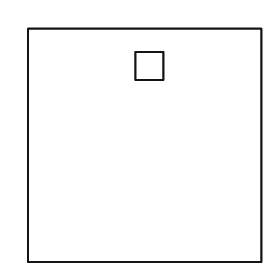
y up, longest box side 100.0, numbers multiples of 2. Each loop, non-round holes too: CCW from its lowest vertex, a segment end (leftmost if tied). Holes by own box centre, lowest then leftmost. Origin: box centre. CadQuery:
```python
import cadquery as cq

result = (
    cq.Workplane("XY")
    .moveTo(-50.0, -50.0)
    .lineTo(50.0, -50.0)
    .lineTo(50.0, 50.0)
    .lineTo(-50.0, 50.0)
    .close()
    .moveTo(-4.0, 28.0)
    .lineTo(8.0, 28.0)
    .lineTo(8.0, 40.0)
    .lineTo(-4.0, 40.0)
    .close()
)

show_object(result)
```